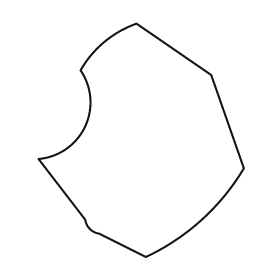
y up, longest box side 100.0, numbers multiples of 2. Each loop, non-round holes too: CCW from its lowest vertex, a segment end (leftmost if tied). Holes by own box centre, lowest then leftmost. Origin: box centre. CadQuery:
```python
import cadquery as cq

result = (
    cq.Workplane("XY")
    .moveTo(2.0, -50.0)
    .threePointArc((26.0, -34.0), (44.0, -12.0))
    .lineTo(30.0, 28.0)
    .lineTo(-2.0, 50.0)
    .threePointArc((-16.0, 42.0), (-26.0, 30.0))
    .threePointArc((-24.0, 6.0), (-44.0, -8.0))
    .lineTo(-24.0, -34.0)
    .threePointArc((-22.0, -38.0), (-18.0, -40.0))
    .close()
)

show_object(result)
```